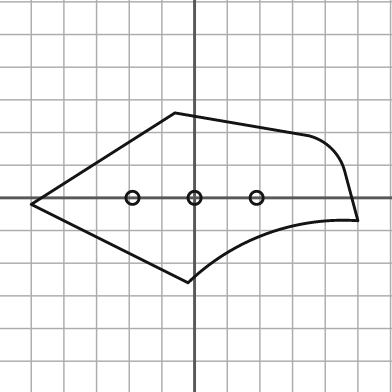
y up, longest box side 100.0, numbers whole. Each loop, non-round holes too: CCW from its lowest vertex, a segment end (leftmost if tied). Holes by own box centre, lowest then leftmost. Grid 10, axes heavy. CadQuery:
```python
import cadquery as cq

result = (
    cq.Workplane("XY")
    .moveTo(-2.0, -26.0)
    .threePointArc((22.0, -11.0), (50.0, -7.0))
    .lineTo(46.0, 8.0)
    .threePointArc((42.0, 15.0), (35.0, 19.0))
    .lineTo(-6.0, 26.0)
    .lineTo(-50.0, -2.0)
    .close()
    .moveTo(-19.0, 0.0)
    .circle(2.0)
    .moveTo(0.0, 0.0)
    .circle(2.0)
    .moveTo(19.0, 0.0)
    .circle(2.0)
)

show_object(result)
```